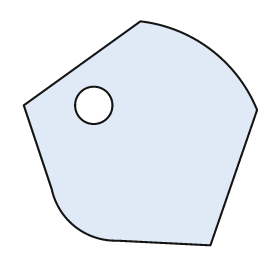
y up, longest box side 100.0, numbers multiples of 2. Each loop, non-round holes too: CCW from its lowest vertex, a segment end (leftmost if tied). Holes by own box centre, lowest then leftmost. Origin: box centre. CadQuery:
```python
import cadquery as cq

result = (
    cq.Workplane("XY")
    .moveTo(30.0, -48.0)
    .lineTo(50.0, 10.0)
    .threePointArc((30.0, 36.0), (0.0, 48.0))
    .lineTo(-50.0, 12.0)
    .lineTo(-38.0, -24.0)
    .threePointArc((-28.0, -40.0), (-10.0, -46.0))
    .close()
    .moveTo(-20.0, 12.0)
    .circle(8.0)
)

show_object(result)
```